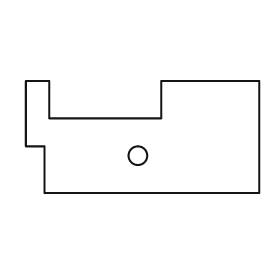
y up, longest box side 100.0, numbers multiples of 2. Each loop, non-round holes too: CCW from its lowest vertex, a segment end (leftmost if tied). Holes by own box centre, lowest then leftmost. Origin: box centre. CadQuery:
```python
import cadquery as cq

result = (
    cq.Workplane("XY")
    .moveTo(-42.0, -24.0)
    .lineTo(50.0, -24.0)
    .lineTo(50.0, 24.0)
    .lineTo(8.0, 24.0)
    .lineTo(8.0, 8.0)
    .lineTo(-40.0, 8.0)
    .lineTo(-40.0, 24.0)
    .lineTo(-50.0, 24.0)
    .lineTo(-50.0, -4.0)
    .lineTo(-42.0, -4.0)
    .close()
    .moveTo(-2.0, -8.0)
    .circle(4.0)
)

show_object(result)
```